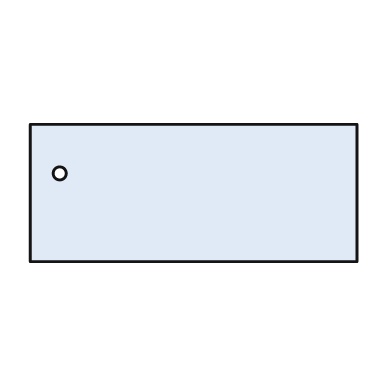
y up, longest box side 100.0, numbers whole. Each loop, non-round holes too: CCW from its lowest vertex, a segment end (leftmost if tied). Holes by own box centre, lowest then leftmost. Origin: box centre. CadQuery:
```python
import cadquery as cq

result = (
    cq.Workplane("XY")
    .moveTo(-50.0, -21.0)
    .lineTo(50.0, -21.0)
    .lineTo(50.0, 21.0)
    .lineTo(-50.0, 21.0)
    .close()
    .moveTo(-41.0, 6.0)
    .circle(2.0)
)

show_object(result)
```